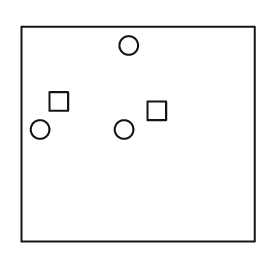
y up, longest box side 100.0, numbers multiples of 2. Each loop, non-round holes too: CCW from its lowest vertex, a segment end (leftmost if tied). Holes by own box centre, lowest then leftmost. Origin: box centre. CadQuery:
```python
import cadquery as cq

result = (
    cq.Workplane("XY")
    .moveTo(-50.0, -46.0)
    .lineTo(50.0, -46.0)
    .lineTo(50.0, 46.0)
    .lineTo(-50.0, 46.0)
    .close()
    .moveTo(-42.0, 2.0)
    .circle(4.0)
    .moveTo(-6.0, 2.0)
    .circle(4.0)
    .moveTo(4.0, 6.0)
    .lineTo(12.0, 6.0)
    .lineTo(12.0, 14.0)
    .lineTo(4.0, 14.0)
    .close()
    .moveTo(-38.0, 10.0)
    .lineTo(-30.0, 10.0)
    .lineTo(-30.0, 18.0)
    .lineTo(-38.0, 18.0)
    .close()
    .moveTo(-4.0, 38.0)
    .circle(4.0)
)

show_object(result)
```